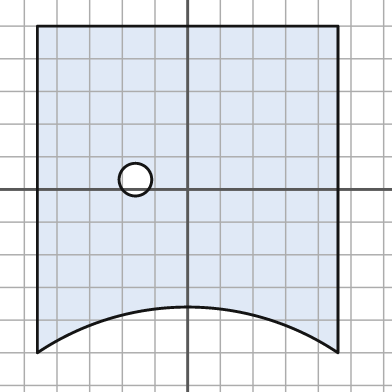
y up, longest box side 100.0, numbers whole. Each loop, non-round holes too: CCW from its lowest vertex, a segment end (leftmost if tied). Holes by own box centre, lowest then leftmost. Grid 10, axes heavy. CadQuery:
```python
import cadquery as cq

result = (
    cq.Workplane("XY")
    .moveTo(-46.0, -50.0)
    .threePointArc((0.0, -36.0), (46.0, -50.0))
    .lineTo(46.0, 50.0)
    .lineTo(-46.0, 50.0)
    .close()
    .moveTo(-16.0, 3.0)
    .circle(5.0)
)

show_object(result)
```